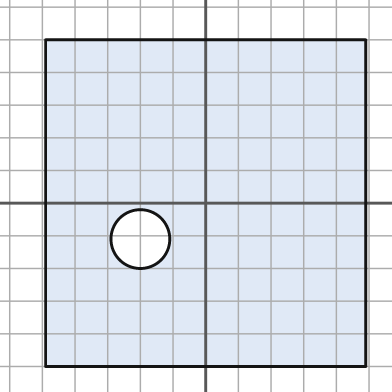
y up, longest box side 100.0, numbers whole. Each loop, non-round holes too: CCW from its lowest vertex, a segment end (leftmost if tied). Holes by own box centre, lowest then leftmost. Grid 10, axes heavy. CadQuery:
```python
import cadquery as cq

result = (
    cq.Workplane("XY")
    .moveTo(-49.0, -50.0)
    .lineTo(49.0, -50.0)
    .lineTo(49.0, 50.0)
    .lineTo(-49.0, 50.0)
    .close()
    .moveTo(-20.0, -11.0)
    .circle(9.0)
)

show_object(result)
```